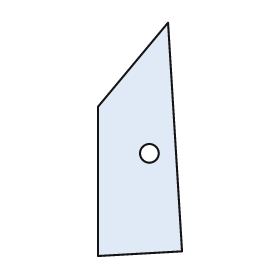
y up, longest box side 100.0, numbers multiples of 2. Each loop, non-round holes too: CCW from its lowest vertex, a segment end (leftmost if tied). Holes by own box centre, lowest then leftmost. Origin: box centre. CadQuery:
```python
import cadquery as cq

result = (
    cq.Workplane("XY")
    .moveTo(-18.0, -50.0)
    .lineTo(18.0, -48.0)
    .lineTo(12.0, 50.0)
    .lineTo(-18.0, 14.0)
    .close()
    .moveTo(4.0, -6.0)
    .circle(4.0)
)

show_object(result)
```